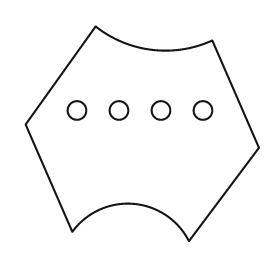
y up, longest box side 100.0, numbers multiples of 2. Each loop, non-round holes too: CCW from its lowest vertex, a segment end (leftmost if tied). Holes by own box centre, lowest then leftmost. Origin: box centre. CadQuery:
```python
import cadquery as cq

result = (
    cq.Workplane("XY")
    .moveTo(20.0, -46.0)
    .lineTo(50.0, -6.0)
    .lineTo(30.0, 40.0)
    .threePointArc((4.0, 36.0), (-20.0, 46.0))
    .lineTo(-50.0, 4.0)
    .lineTo(-30.0, -42.0)
    .threePointArc((-4.0, -30.0), (20.0, -46.0))
    .close()
    .moveTo(-28.0, 10.0)
    .circle(4.0)
    .moveTo(-10.0, 10.0)
    .circle(4.0)
    .moveTo(8.0, 10.0)
    .circle(4.0)
    .moveTo(26.0, 10.0)
    .circle(4.0)
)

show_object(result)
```